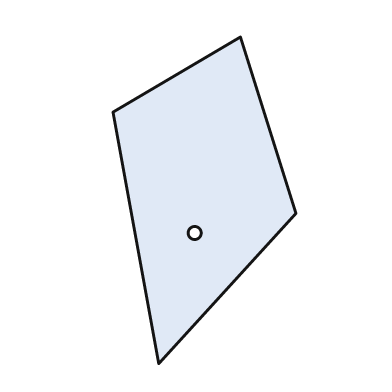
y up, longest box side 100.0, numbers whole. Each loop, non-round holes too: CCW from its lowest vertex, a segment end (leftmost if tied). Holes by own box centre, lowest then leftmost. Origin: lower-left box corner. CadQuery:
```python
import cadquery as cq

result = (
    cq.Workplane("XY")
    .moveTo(14.0, 0.0)
    .lineTo(56.0, 46.0)
    .lineTo(39.0, 100.0)
    .lineTo(0.0, 77.0)
    .close()
    .moveTo(25.0, 40.0)
    .circle(2.0)
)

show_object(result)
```